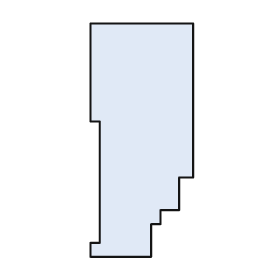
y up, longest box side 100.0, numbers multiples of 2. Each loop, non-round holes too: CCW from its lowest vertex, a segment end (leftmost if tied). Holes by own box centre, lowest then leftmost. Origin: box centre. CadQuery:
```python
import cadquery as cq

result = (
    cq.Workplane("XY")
    .moveTo(-22.0, -50.0)
    .lineTo(4.0, -50.0)
    .lineTo(4.0, -36.0)
    .lineTo(8.0, -36.0)
    .lineTo(8.0, -30.0)
    .lineTo(16.0, -30.0)
    .lineTo(16.0, -16.0)
    .lineTo(22.0, -16.0)
    .lineTo(22.0, 50.0)
    .lineTo(-22.0, 50.0)
    .lineTo(-22.0, 8.0)
    .lineTo(-18.0, 8.0)
    .lineTo(-18.0, -44.0)
    .lineTo(-22.0, -44.0)
    .close()
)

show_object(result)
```